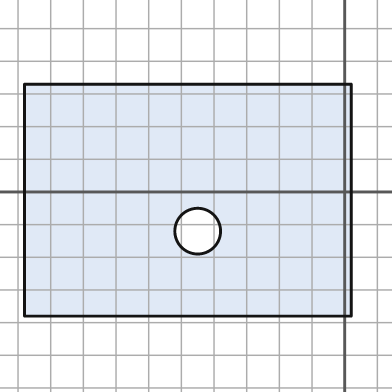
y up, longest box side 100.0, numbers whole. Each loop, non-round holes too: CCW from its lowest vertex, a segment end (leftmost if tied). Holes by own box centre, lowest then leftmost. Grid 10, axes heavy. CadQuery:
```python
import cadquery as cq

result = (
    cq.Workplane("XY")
    .moveTo(-98.0, -38.0)
    .lineTo(2.0, -38.0)
    .lineTo(2.0, 33.0)
    .lineTo(-98.0, 33.0)
    .close()
    .moveTo(-45.0, -12.0)
    .circle(7.0)
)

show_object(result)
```